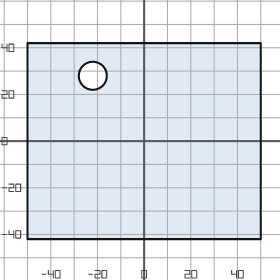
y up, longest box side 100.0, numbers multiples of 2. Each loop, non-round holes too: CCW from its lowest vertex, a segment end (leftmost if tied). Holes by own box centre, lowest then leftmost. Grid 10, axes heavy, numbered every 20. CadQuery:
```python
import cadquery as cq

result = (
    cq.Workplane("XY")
    .moveTo(-50.0, -42.0)
    .lineTo(50.0, -42.0)
    .lineTo(50.0, 42.0)
    .lineTo(-50.0, 42.0)
    .close()
    .moveTo(-22.0, 28.0)
    .circle(6.0)
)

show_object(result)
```